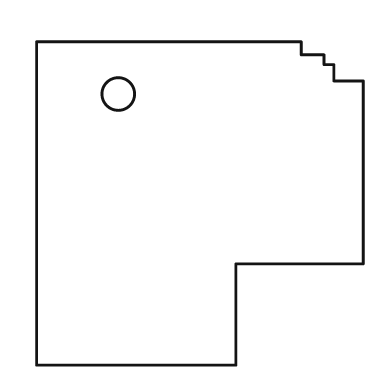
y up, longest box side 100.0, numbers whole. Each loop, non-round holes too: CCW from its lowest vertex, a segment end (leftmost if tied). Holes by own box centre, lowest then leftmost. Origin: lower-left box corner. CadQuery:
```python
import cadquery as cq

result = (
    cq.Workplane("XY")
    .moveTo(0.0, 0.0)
    .lineTo(61.0, 0.0)
    .lineTo(61.0, 31.0)
    .lineTo(100.0, 31.0)
    .lineTo(100.0, 87.0)
    .lineTo(91.0, 87.0)
    .lineTo(91.0, 92.0)
    .lineTo(88.0, 92.0)
    .lineTo(88.0, 95.0)
    .lineTo(81.0, 95.0)
    .lineTo(81.0, 99.0)
    .lineTo(0.0, 99.0)
    .close()
    .moveTo(25.0, 83.0)
    .circle(5.0)
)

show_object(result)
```